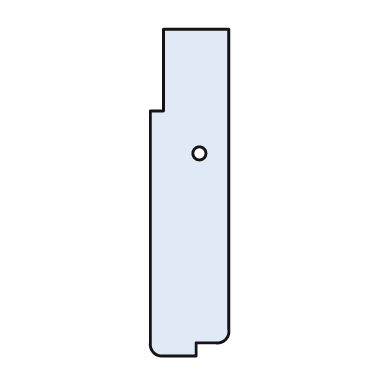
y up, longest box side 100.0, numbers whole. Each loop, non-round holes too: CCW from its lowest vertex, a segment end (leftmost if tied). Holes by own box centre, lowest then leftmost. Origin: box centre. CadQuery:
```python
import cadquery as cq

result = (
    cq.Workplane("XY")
    .moveTo(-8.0, -50.0)
    .lineTo(2.0, -50.0)
    .lineTo(2.0, -46.0)
    .lineTo(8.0, -46.0)
    .threePointArc((11.0, -45.0), (12.0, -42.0))
    .lineTo(12.0, 50.0)
    .lineTo(-8.0, 50.0)
    .lineTo(-8.0, 25.0)
    .lineTo(-12.0, 25.0)
    .lineTo(-12.0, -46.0)
    .threePointArc((-11.0, -49.0), (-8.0, -50.0))
    .close()
    .moveTo(3.0, 12.0)
    .circle(2.0)
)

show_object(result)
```